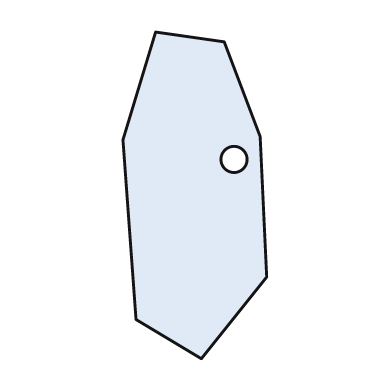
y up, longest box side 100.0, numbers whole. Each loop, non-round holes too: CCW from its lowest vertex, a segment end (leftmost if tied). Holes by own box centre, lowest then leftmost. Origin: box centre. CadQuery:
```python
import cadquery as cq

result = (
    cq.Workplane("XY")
    .moveTo(2.0, -50.0)
    .lineTo(22.0, -25.0)
    .lineTo(20.0, 18.0)
    .lineTo(9.0, 47.0)
    .lineTo(-12.0, 50.0)
    .lineTo(-22.0, 17.0)
    .lineTo(-18.0, -38.0)
    .close()
    .moveTo(12.0, 11.0)
    .circle(4.0)
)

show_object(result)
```